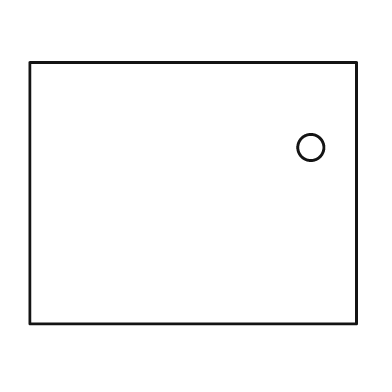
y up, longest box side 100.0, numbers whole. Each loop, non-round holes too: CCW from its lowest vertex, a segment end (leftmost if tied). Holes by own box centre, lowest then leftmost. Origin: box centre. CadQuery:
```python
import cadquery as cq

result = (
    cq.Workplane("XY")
    .moveTo(-50.0, -40.0)
    .lineTo(50.0, -40.0)
    .lineTo(50.0, 40.0)
    .lineTo(-50.0, 40.0)
    .close()
    .moveTo(36.0, 14.0)
    .circle(4.0)
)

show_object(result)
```